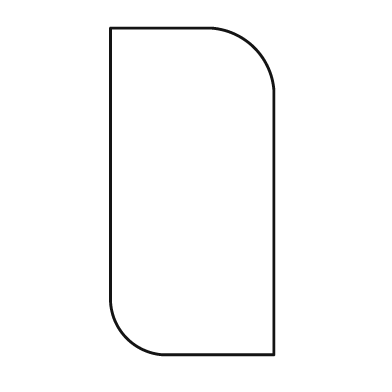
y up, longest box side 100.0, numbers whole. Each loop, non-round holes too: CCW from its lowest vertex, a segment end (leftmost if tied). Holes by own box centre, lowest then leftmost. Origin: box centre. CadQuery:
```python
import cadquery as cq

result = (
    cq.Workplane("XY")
    .moveTo(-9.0, -50.0)
    .lineTo(25.0, -50.0)
    .lineTo(25.0, 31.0)
    .threePointArc((19.0, 44.0), (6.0, 50.0))
    .lineTo(-25.0, 50.0)
    .lineTo(-25.0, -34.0)
    .threePointArc((-20.0, -45.0), (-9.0, -50.0))
    .close()
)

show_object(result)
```